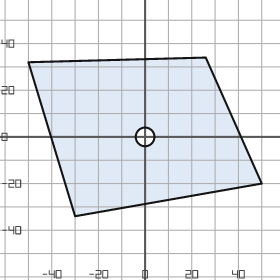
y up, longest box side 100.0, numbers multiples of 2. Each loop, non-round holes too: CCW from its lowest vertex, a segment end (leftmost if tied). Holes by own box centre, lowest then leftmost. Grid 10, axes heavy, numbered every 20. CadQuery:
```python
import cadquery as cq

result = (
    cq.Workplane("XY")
    .moveTo(-30.0, -34.0)
    .lineTo(50.0, -20.0)
    .lineTo(26.0, 34.0)
    .lineTo(-50.0, 32.0)
    .close()
    .moveTo(0.0, 0.0)
    .circle(4.0)
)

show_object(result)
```